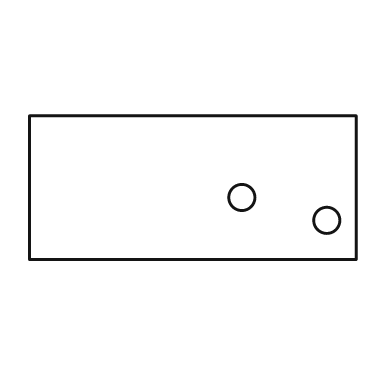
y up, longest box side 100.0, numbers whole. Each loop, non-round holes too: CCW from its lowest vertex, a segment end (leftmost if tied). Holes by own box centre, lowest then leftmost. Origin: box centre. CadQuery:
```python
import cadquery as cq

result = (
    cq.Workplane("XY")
    .moveTo(-50.0, -22.0)
    .lineTo(50.0, -22.0)
    .lineTo(50.0, 22.0)
    .lineTo(-50.0, 22.0)
    .close()
    .moveTo(41.0, -10.0)
    .circle(4.0)
    .moveTo(15.0, -3.0)
    .circle(4.0)
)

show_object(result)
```